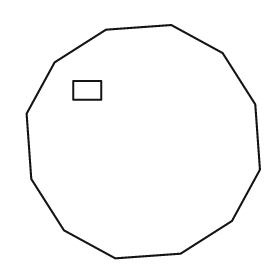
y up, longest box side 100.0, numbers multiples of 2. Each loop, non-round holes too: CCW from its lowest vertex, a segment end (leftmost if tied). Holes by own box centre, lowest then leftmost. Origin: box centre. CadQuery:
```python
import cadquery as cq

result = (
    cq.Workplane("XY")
    .moveTo(-12.0, -50.0)
    .lineTo(16.0, -48.0)
    .lineTo(38.0, -34.0)
    .lineTo(50.0, -12.0)
    .lineTo(48.0, 16.0)
    .lineTo(34.0, 38.0)
    .lineTo(12.0, 50.0)
    .lineTo(-16.0, 48.0)
    .lineTo(-38.0, 34.0)
    .lineTo(-50.0, 12.0)
    .lineTo(-48.0, -16.0)
    .lineTo(-34.0, -38.0)
    .close()
    .moveTo(-30.0, 18.0)
    .lineTo(-18.0, 18.0)
    .lineTo(-18.0, 26.0)
    .lineTo(-30.0, 26.0)
    .close()
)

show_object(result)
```